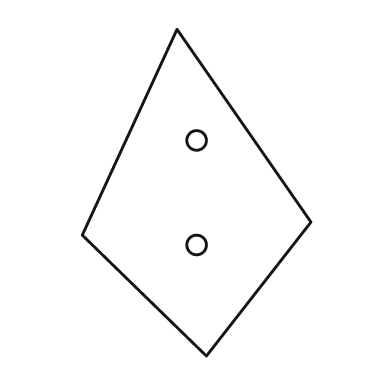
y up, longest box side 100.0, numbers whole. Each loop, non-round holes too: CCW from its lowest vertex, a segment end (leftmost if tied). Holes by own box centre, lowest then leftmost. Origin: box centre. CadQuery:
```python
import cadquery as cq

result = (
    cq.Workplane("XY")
    .moveTo(3.0, -50.0)
    .lineTo(35.0, -9.0)
    .lineTo(-6.0, 50.0)
    .lineTo(-35.0, -13.0)
    .close()
    .moveTo(0.0, -16.0)
    .circle(3.0)
    .moveTo(0.0, 16.0)
    .circle(3.0)
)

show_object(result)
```